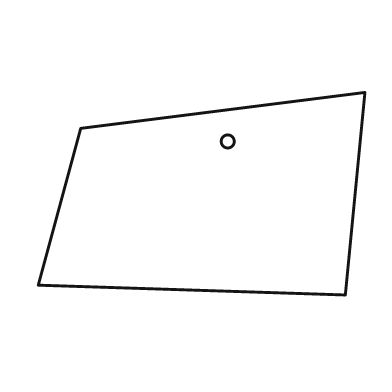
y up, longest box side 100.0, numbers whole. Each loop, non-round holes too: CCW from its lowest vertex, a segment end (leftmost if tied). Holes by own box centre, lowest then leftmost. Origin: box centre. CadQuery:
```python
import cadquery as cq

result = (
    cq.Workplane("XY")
    .moveTo(44.0, -31.0)
    .lineTo(50.0, 31.0)
    .lineTo(-37.0, 20.0)
    .lineTo(-50.0, -28.0)
    .close()
    .moveTo(8.0, 16.0)
    .circle(2.0)
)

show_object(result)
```